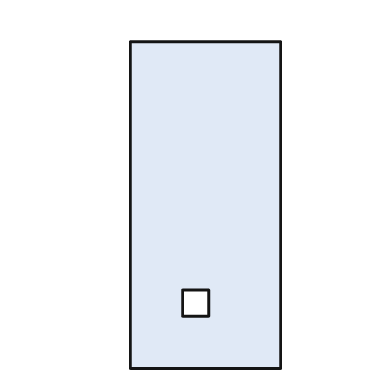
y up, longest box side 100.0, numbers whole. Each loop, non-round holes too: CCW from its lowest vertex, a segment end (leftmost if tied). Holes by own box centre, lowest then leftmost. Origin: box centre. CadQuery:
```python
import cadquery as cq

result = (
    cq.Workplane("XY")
    .moveTo(-23.0, -50.0)
    .lineTo(23.0, -50.0)
    .lineTo(23.0, 50.0)
    .lineTo(-23.0, 50.0)
    .close()
    .moveTo(-7.0, -34.0)
    .lineTo(1.0, -34.0)
    .lineTo(1.0, -26.0)
    .lineTo(-7.0, -26.0)
    .close()
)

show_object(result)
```